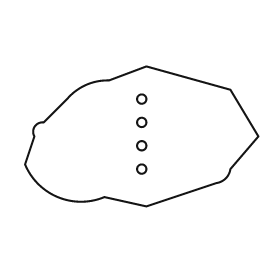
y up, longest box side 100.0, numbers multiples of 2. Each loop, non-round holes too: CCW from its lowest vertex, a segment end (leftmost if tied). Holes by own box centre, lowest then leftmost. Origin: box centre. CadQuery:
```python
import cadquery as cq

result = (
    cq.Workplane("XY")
    .moveTo(2.0, -30.0)
    .lineTo(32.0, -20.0)
    .threePointArc((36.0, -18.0), (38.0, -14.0))
    .lineTo(50.0, 0.0)
    .lineTo(38.0, 20.0)
    .lineTo(2.0, 30.0)
    .lineTo(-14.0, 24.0)
    .threePointArc((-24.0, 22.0), (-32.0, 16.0))
    .lineTo(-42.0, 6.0)
    .threePointArc((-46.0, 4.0), (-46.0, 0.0))
    .lineTo(-50.0, -12.0)
    .threePointArc((-36.0, -26.0), (-16.0, -26.0))
    .close()
    .moveTo(0.0, -14.0)
    .circle(2.0)
    .moveTo(0.0, -4.0)
    .circle(2.0)
    .moveTo(0.0, 6.0)
    .circle(2.0)
    .moveTo(0.0, 16.0)
    .circle(2.0)
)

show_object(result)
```